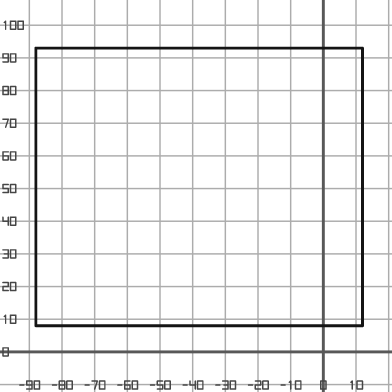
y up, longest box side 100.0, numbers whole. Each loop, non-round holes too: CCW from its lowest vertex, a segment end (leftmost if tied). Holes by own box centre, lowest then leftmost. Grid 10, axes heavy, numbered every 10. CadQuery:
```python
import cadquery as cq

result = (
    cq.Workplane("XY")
    .moveTo(-88.0, 8.0)
    .lineTo(12.0, 8.0)
    .lineTo(12.0, 93.0)
    .lineTo(-88.0, 93.0)
    .close()
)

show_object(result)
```